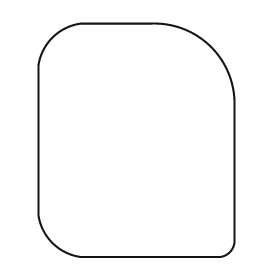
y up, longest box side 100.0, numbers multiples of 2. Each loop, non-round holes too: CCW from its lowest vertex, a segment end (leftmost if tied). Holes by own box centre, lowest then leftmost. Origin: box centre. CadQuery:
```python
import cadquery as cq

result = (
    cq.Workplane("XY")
    .moveTo(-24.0, -50.0)
    .lineTo(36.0, -50.0)
    .threePointArc((40.0, -48.0), (42.0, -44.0))
    .lineTo(42.0, 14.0)
    .threePointArc((32.0, 40.0), (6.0, 50.0))
    .lineTo(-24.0, 50.0)
    .threePointArc((-36.0, 44.0), (-42.0, 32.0))
    .lineTo(-42.0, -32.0)
    .threePointArc((-36.0, -44.0), (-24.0, -50.0))
    .close()
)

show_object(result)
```